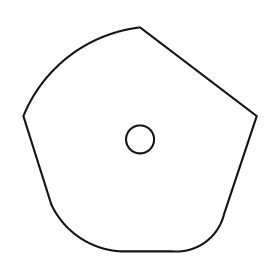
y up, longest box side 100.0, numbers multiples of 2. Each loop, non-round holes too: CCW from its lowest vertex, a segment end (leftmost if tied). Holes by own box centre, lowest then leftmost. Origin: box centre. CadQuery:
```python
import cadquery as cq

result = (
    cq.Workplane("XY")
    .moveTo(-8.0, -48.0)
    .lineTo(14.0, -48.0)
    .threePointArc((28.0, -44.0), (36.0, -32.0))
    .lineTo(50.0, 10.0)
    .lineTo(0.0, 48.0)
    .threePointArc((-30.0, 36.0), (-50.0, 10.0))
    .lineTo(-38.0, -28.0)
    .threePointArc((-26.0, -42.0), (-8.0, -48.0))
    .close()
    .moveTo(0.0, 0.0)
    .circle(6.0)
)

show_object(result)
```